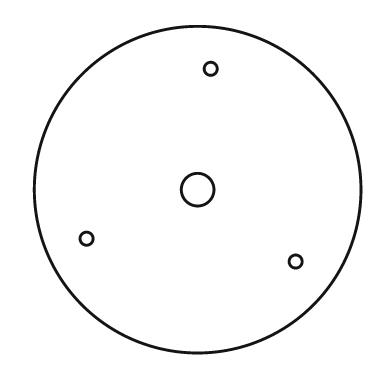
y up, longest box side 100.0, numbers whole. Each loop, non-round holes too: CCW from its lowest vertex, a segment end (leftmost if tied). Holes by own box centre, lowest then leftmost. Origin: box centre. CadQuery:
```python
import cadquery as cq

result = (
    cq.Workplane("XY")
    .moveTo(0.0, 0.0)
    .circle(50.0)
    .moveTo(30.0, -22.0)
    .circle(2.0)
    .moveTo(-34.0, -15.0)
    .circle(2.0)
    .moveTo(0.0, 0.0)
    .circle(5.0)
    .moveTo(4.0, 37.0)
    .circle(2.0)
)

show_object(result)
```